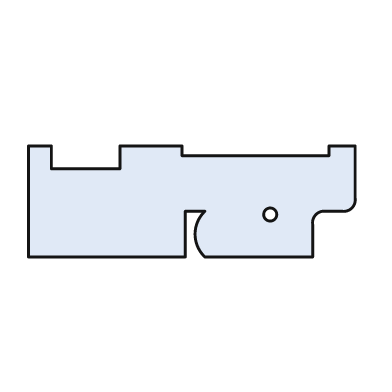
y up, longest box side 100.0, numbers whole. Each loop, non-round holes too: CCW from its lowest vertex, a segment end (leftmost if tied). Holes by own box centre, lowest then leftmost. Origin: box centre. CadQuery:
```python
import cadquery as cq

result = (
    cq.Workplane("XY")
    .moveTo(-50.0, -17.0)
    .lineTo(-2.0, -17.0)
    .lineTo(-2.0, -3.0)
    .lineTo(4.0, -3.0)
    .threePointArc((1.0, -10.0), (4.0, -17.0))
    .lineTo(37.0, -17.0)
    .lineTo(37.0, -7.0)
    .threePointArc((38.0, -4.0), (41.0, -3.0))
    .lineTo(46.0, -3.0)
    .threePointArc((49.0, -2.0), (50.0, 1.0))
    .lineTo(50.0, 17.0)
    .lineTo(42.0, 17.0)
    .lineTo(42.0, 14.0)
    .lineTo(-3.0, 14.0)
    .lineTo(-3.0, 17.0)
    .lineTo(-22.0, 17.0)
    .lineTo(-22.0, 10.0)
    .lineTo(-43.0, 10.0)
    .lineTo(-43.0, 17.0)
    .lineTo(-50.0, 17.0)
    .close()
    .moveTo(24.0, -4.0)
    .circle(2.0)
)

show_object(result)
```